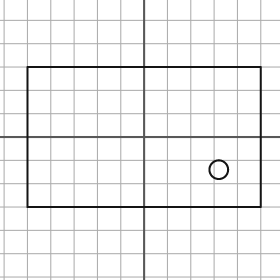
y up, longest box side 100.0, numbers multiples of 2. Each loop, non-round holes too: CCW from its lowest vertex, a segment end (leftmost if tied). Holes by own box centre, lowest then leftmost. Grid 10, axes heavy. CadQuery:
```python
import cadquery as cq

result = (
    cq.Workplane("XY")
    .moveTo(-50.0, -30.0)
    .lineTo(50.0, -30.0)
    .lineTo(50.0, 30.0)
    .lineTo(-50.0, 30.0)
    .close()
    .moveTo(32.0, -14.0)
    .circle(4.0)
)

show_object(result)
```